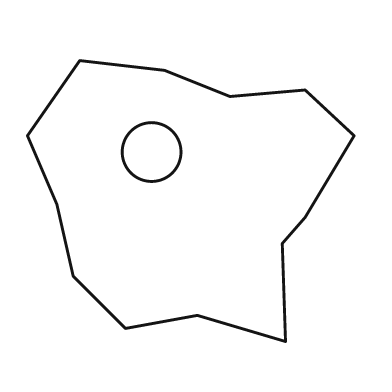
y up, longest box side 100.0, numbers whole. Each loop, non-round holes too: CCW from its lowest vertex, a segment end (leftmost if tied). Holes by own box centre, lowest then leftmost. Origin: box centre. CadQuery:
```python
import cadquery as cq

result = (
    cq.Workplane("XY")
    .moveTo(29.0, -43.0)
    .lineTo(28.0, -13.0)
    .lineTo(35.0, -5.0)
    .lineTo(50.0, 20.0)
    .lineTo(35.0, 34.0)
    .lineTo(12.0, 32.0)
    .lineTo(-8.0, 40.0)
    .lineTo(-34.0, 43.0)
    .lineTo(-50.0, 20.0)
    .lineTo(-41.0, -1.0)
    .lineTo(-36.0, -23.0)
    .lineTo(-20.0, -39.0)
    .lineTo(2.0, -35.0)
    .close()
    .moveTo(-12.0, 15.0)
    .circle(9.0)
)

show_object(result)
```